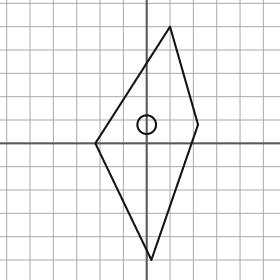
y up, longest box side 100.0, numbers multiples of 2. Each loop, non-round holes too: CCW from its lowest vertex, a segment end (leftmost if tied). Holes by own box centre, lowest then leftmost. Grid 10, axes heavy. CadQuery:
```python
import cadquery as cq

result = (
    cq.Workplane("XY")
    .moveTo(2.0, -50.0)
    .lineTo(22.0, 8.0)
    .lineTo(10.0, 50.0)
    .lineTo(-22.0, 0.0)
    .close()
    .moveTo(0.0, 8.0)
    .circle(4.0)
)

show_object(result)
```